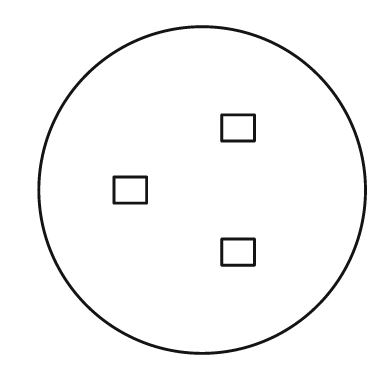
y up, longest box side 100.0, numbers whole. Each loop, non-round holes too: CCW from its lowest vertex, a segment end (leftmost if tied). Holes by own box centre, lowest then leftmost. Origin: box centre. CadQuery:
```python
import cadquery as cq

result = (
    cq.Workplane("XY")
    .moveTo(0.0, 0.0)
    .circle(50.0)
    .moveTo(6.0, -23.0)
    .lineTo(16.0, -23.0)
    .lineTo(16.0, -15.0)
    .lineTo(6.0, -15.0)
    .close()
    .moveTo(-27.0, -4.0)
    .lineTo(-17.0, -4.0)
    .lineTo(-17.0, 4.0)
    .lineTo(-27.0, 4.0)
    .close()
    .moveTo(6.0, 15.0)
    .lineTo(16.0, 15.0)
    .lineTo(16.0, 23.0)
    .lineTo(6.0, 23.0)
    .close()
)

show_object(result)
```